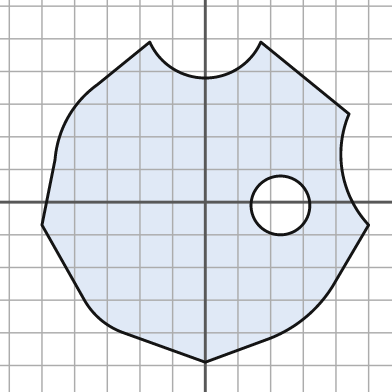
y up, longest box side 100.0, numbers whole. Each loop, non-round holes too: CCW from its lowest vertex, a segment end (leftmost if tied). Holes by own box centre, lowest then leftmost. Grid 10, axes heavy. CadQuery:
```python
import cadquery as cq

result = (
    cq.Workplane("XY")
    .moveTo(0.0, -49.0)
    .lineTo(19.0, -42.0)
    .threePointArc((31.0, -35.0), (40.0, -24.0))
    .lineTo(50.0, -7.0)
    .threePointArc((42.0, 9.0), (44.0, 27.0))
    .lineTo(17.0, 49.0)
    .threePointArc((0.0, 38.0), (-17.0, 49.0))
    .lineTo(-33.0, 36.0)
    .threePointArc((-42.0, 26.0), (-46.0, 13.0))
    .lineTo(-50.0, -7.0)
    .lineTo(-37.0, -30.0)
    .threePointArc((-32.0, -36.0), (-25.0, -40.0))
    .close()
    .moveTo(23.0, -1.0)
    .circle(9.0)
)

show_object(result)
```